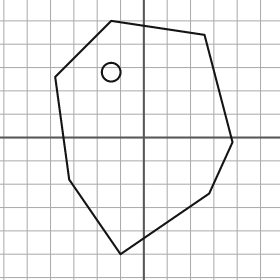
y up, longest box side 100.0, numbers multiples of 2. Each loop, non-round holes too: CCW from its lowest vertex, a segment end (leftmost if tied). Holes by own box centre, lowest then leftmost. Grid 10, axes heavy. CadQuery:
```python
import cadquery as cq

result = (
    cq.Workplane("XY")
    .moveTo(-10.0, -50.0)
    .lineTo(28.0, -24.0)
    .lineTo(38.0, -2.0)
    .lineTo(26.0, 44.0)
    .lineTo(-14.0, 50.0)
    .lineTo(-38.0, 26.0)
    .lineTo(-32.0, -18.0)
    .close()
    .moveTo(-14.0, 28.0)
    .circle(4.0)
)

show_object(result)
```